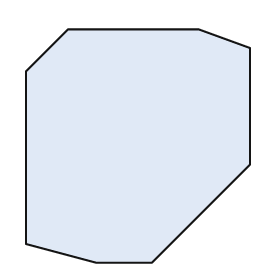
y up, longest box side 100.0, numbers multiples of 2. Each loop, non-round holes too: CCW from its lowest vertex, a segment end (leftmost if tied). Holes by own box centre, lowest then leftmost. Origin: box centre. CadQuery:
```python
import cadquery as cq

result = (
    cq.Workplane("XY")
    .moveTo(-18.0, -50.0)
    .lineTo(6.0, -50.0)
    .lineTo(48.0, -8.0)
    .lineTo(48.0, 42.0)
    .lineTo(26.0, 50.0)
    .lineTo(-30.0, 50.0)
    .lineTo(-48.0, 32.0)
    .lineTo(-48.0, -42.0)
    .close()
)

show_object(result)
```